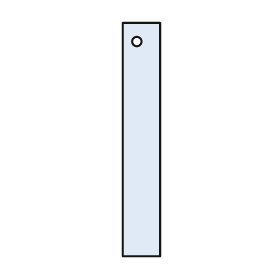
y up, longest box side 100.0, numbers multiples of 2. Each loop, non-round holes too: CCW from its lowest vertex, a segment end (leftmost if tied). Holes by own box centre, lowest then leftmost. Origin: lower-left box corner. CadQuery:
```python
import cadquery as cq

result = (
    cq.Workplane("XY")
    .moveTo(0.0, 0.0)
    .lineTo(16.0, 0.0)
    .lineTo(16.0, 100.0)
    .lineTo(0.0, 100.0)
    .close()
    .moveTo(6.0, 92.0)
    .circle(2.0)
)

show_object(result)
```